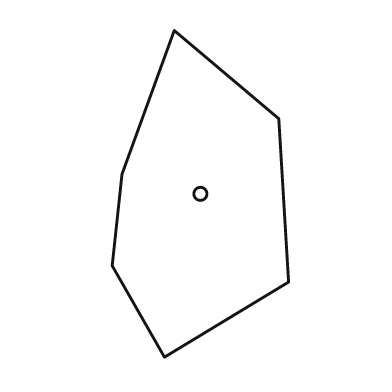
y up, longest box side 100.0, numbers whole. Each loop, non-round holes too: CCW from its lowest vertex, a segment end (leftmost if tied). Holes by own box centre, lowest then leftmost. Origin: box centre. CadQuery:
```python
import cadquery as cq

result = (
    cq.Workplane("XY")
    .moveTo(-11.0, -50.0)
    .lineTo(27.0, -27.0)
    .lineTo(24.0, 23.0)
    .lineTo(-8.0, 50.0)
    .lineTo(-24.0, 6.0)
    .lineTo(-27.0, -22.0)
    .close()
    .moveTo(0.0, 0.0)
    .circle(2.0)
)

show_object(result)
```